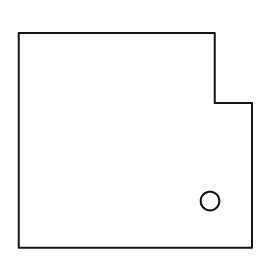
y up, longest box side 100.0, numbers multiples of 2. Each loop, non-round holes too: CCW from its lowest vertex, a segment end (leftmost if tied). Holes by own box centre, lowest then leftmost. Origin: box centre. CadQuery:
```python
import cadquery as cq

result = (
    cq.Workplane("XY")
    .moveTo(-50.0, -46.0)
    .lineTo(50.0, -46.0)
    .lineTo(50.0, 16.0)
    .lineTo(34.0, 16.0)
    .lineTo(34.0, 46.0)
    .lineTo(-50.0, 46.0)
    .close()
    .moveTo(32.0, -26.0)
    .circle(4.0)
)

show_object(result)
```